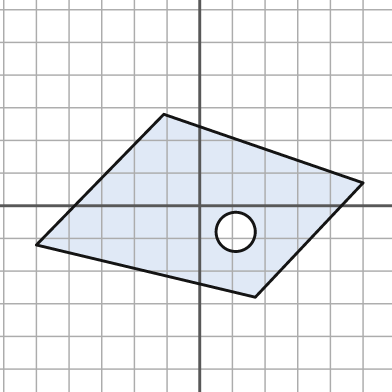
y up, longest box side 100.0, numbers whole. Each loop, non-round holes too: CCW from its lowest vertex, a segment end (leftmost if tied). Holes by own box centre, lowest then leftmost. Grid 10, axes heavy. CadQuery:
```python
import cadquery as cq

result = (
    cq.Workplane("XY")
    .moveTo(17.0, -28.0)
    .lineTo(50.0, 7.0)
    .lineTo(-11.0, 28.0)
    .lineTo(-50.0, -12.0)
    .close()
    .moveTo(11.0, -8.0)
    .circle(6.0)
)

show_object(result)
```